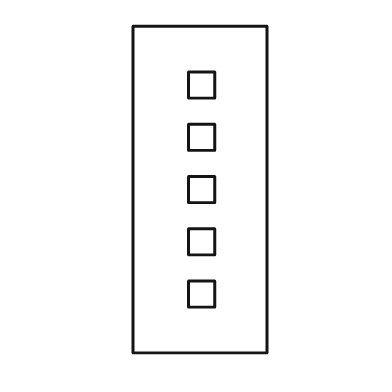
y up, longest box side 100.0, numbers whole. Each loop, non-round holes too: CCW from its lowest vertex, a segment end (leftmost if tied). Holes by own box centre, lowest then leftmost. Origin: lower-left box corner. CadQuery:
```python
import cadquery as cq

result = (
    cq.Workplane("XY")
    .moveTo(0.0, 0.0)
    .lineTo(41.0, 0.0)
    .lineTo(41.0, 100.0)
    .lineTo(0.0, 100.0)
    .close()
    .moveTo(17.0, 14.0)
    .lineTo(25.0, 14.0)
    .lineTo(25.0, 22.0)
    .lineTo(17.0, 22.0)
    .close()
    .moveTo(17.0, 30.0)
    .lineTo(25.0, 30.0)
    .lineTo(25.0, 38.0)
    .lineTo(17.0, 38.0)
    .close()
    .moveTo(17.0, 46.0)
    .lineTo(25.0, 46.0)
    .lineTo(25.0, 54.0)
    .lineTo(17.0, 54.0)
    .close()
    .moveTo(17.0, 62.0)
    .lineTo(25.0, 62.0)
    .lineTo(25.0, 70.0)
    .lineTo(17.0, 70.0)
    .close()
    .moveTo(17.0, 78.0)
    .lineTo(25.0, 78.0)
    .lineTo(25.0, 86.0)
    .lineTo(17.0, 86.0)
    .close()
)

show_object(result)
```